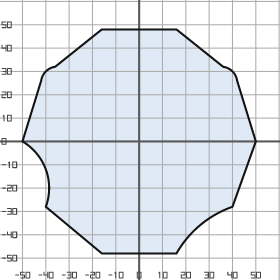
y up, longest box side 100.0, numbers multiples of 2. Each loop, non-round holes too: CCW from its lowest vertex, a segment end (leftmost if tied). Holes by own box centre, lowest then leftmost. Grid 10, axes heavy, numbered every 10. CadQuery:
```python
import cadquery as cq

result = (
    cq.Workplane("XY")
    .moveTo(-16.0, -48.0)
    .lineTo(16.0, -48.0)
    .threePointArc((26.0, -36.0), (40.0, -28.0))
    .lineTo(50.0, 0.0)
    .lineTo(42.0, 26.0)
    .threePointArc((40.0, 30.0), (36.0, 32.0))
    .lineTo(16.0, 48.0)
    .lineTo(-16.0, 48.0)
    .lineTo(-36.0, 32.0)
    .threePointArc((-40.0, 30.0), (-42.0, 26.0))
    .lineTo(-50.0, 0.0)
    .threePointArc((-40.0, -12.0), (-40.0, -28.0))
    .close()
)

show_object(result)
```